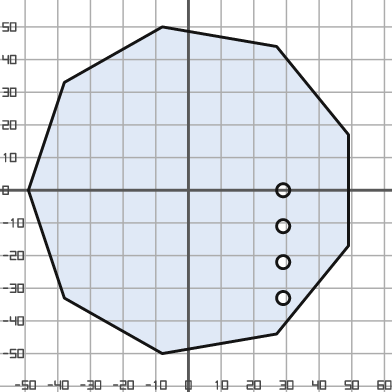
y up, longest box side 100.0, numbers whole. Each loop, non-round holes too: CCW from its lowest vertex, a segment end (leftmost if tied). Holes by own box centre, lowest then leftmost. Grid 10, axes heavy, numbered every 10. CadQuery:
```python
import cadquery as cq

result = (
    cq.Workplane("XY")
    .moveTo(-8.0, -50.0)
    .lineTo(27.0, -44.0)
    .lineTo(49.0, -17.0)
    .lineTo(49.0, 17.0)
    .lineTo(27.0, 44.0)
    .lineTo(-8.0, 50.0)
    .lineTo(-38.0, 33.0)
    .lineTo(-49.0, 0.0)
    .lineTo(-38.0, -33.0)
    .close()
    .moveTo(29.0, -33.0)
    .circle(2.0)
    .moveTo(29.0, -22.0)
    .circle(2.0)
    .moveTo(29.0, -11.0)
    .circle(2.0)
    .moveTo(29.0, 0.0)
    .circle(2.0)
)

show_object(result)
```